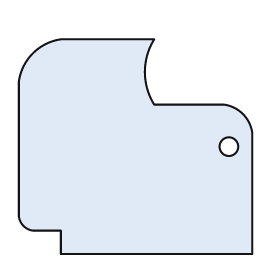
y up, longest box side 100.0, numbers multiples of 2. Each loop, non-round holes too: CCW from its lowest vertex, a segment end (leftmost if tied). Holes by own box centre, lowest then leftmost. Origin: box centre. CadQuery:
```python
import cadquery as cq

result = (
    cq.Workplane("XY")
    .moveTo(-32.0, -46.0)
    .lineTo(50.0, -46.0)
    .lineTo(50.0, 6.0)
    .threePointArc((46.0, 14.0), (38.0, 18.0))
    .lineTo(8.0, 18.0)
    .threePointArc((4.0, 32.0), (8.0, 46.0))
    .lineTo(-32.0, 46.0)
    .threePointArc((-44.0, 40.0), (-50.0, 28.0))
    .lineTo(-50.0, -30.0)
    .threePointArc((-48.0, -34.0), (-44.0, -36.0))
    .lineTo(-32.0, -36.0)
    .close()
    .moveTo(40.0, 0.0)
    .circle(4.0)
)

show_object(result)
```